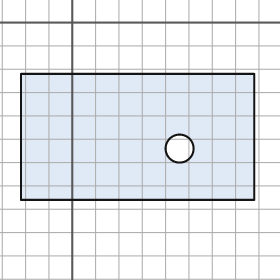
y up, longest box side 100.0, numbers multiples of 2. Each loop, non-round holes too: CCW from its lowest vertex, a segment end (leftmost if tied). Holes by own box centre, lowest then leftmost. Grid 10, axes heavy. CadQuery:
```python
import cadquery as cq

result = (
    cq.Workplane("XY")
    .moveTo(-22.0, -76.0)
    .lineTo(78.0, -76.0)
    .lineTo(78.0, -22.0)
    .lineTo(-22.0, -22.0)
    .close()
    .moveTo(46.0, -54.0)
    .circle(6.0)
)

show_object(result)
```